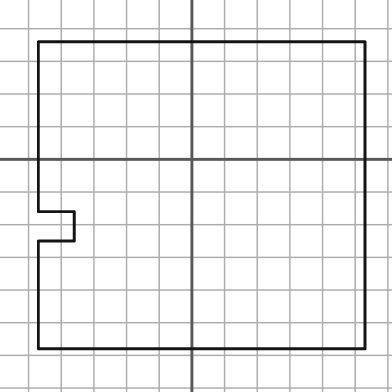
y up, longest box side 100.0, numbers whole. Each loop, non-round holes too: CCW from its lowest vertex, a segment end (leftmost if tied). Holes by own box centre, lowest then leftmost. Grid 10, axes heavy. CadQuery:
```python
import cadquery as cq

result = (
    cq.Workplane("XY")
    .moveTo(-47.0, -58.0)
    .lineTo(53.0, -58.0)
    .lineTo(53.0, 36.0)
    .lineTo(-47.0, 36.0)
    .lineTo(-47.0, -16.0)
    .lineTo(-36.0, -16.0)
    .lineTo(-36.0, -25.0)
    .lineTo(-47.0, -25.0)
    .close()
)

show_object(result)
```